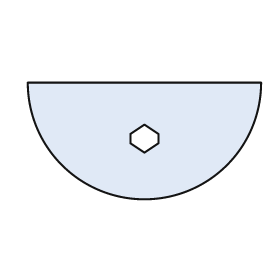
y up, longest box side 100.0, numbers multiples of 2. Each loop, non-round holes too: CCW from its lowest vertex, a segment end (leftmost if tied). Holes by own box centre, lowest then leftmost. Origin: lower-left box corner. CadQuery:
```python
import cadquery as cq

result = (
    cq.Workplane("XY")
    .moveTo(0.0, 50.0)
    .threePointArc((50.0, 0.0), (100.0, 50.0))
    .close()
    .moveTo(50.0, 20.0)
    .lineTo(56.0, 24.0)
    .lineTo(56.0, 28.0)
    .lineTo(50.0, 32.0)
    .lineTo(44.0, 28.0)
    .lineTo(44.0, 24.0)
    .close()
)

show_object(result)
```